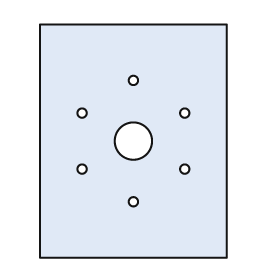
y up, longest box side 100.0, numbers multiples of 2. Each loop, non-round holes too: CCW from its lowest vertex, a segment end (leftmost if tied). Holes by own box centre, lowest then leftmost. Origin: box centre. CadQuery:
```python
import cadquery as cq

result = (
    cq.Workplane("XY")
    .moveTo(-40.0, -50.0)
    .lineTo(40.0, -50.0)
    .lineTo(40.0, 50.0)
    .lineTo(-40.0, 50.0)
    .close()
    .moveTo(0.0, -26.0)
    .circle(2.0)
    .moveTo(-22.0, -12.0)
    .circle(2.0)
    .moveTo(22.0, -12.0)
    .circle(2.0)
    .moveTo(0.0, 0.0)
    .circle(8.0)
    .moveTo(-22.0, 12.0)
    .circle(2.0)
    .moveTo(22.0, 12.0)
    .circle(2.0)
    .moveTo(0.0, 26.0)
    .circle(2.0)
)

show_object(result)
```